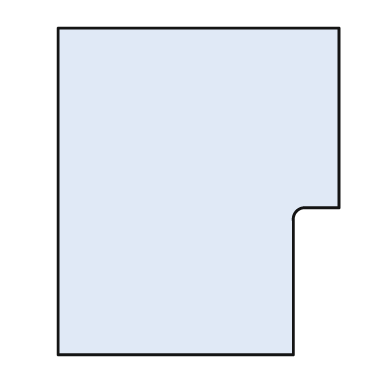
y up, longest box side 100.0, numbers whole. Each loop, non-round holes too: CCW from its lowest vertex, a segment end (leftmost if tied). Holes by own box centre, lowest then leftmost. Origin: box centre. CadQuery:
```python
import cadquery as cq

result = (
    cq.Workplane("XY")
    .moveTo(-43.0, -50.0)
    .lineTo(29.0, -50.0)
    .lineTo(29.0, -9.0)
    .threePointArc((30.0, -6.0), (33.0, -5.0))
    .lineTo(43.0, -5.0)
    .lineTo(43.0, 50.0)
    .lineTo(-43.0, 50.0)
    .close()
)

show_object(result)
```